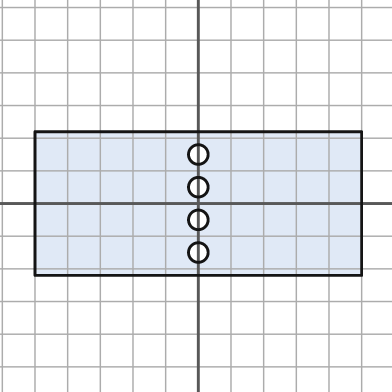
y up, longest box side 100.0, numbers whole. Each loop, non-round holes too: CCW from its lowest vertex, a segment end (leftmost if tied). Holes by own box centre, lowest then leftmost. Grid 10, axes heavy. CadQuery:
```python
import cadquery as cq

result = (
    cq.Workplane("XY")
    .moveTo(-50.0, -22.0)
    .lineTo(50.0, -22.0)
    .lineTo(50.0, 22.0)
    .lineTo(-50.0, 22.0)
    .close()
    .moveTo(0.0, -15.0)
    .circle(3.0)
    .moveTo(0.0, -5.0)
    .circle(3.0)
    .moveTo(0.0, 5.0)
    .circle(3.0)
    .moveTo(0.0, 15.0)
    .circle(3.0)
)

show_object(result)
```